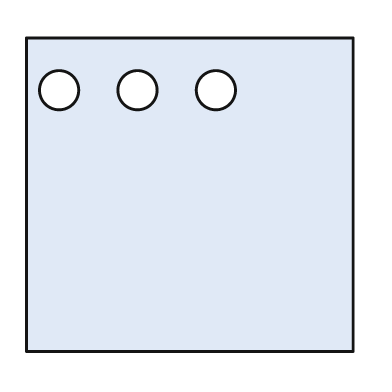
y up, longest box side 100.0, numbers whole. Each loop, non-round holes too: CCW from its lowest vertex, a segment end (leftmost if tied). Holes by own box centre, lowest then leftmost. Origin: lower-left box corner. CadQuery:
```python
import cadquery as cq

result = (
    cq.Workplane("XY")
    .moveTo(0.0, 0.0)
    .lineTo(100.0, 0.0)
    .lineTo(100.0, 96.0)
    .lineTo(0.0, 96.0)
    .close()
    .moveTo(10.0, 80.0)
    .circle(6.0)
    .moveTo(34.0, 80.0)
    .circle(6.0)
    .moveTo(58.0, 80.0)
    .circle(6.0)
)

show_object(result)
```